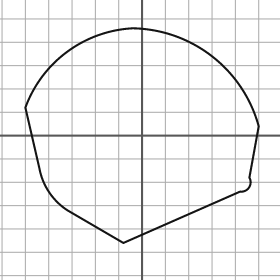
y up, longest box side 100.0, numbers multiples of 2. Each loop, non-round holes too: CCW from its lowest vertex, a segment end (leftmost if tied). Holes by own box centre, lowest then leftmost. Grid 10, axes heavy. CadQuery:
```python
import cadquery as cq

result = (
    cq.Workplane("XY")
    .moveTo(-8.0, -46.0)
    .lineTo(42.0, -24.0)
    .threePointArc((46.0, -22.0), (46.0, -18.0))
    .lineTo(50.0, 4.0)
    .threePointArc((30.0, 34.0), (-4.0, 46.0))
    .threePointArc((-32.0, 36.0), (-50.0, 12.0))
    .lineTo(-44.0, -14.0)
    .threePointArc((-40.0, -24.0), (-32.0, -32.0))
    .close()
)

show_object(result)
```